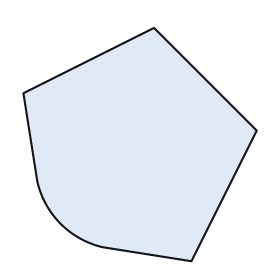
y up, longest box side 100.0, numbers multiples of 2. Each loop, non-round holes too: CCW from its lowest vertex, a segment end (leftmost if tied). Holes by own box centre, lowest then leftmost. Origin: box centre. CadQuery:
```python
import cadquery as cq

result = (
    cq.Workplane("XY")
    .moveTo(22.0, -50.0)
    .lineTo(50.0, 6.0)
    .lineTo(6.0, 50.0)
    .lineTo(-50.0, 22.0)
    .lineTo(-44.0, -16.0)
    .threePointArc((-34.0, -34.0), (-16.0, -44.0))
    .close()
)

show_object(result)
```